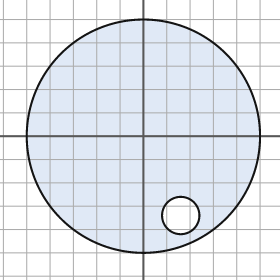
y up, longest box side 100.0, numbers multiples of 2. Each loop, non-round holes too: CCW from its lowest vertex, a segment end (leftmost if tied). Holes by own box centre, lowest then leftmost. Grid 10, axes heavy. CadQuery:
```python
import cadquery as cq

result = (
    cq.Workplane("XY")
    .moveTo(0.0, 0.0)
    .circle(50.0)
    .moveTo(16.0, -34.0)
    .circle(8.0)
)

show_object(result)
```